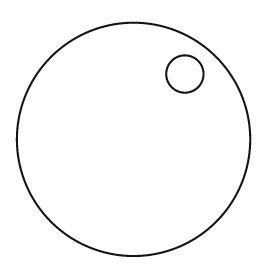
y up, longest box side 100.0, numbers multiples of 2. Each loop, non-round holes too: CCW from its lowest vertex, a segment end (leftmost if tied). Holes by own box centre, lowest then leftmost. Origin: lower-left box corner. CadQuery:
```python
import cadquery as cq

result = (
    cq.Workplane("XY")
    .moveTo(50.0, 50.0)
    .circle(50.0)
    .moveTo(72.0, 78.0)
    .circle(8.0)
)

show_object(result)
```